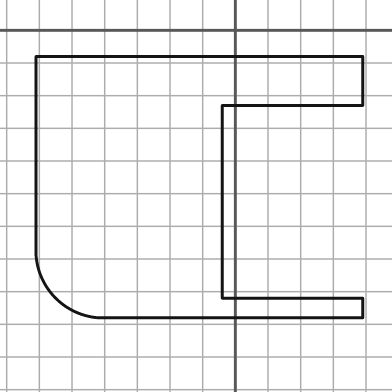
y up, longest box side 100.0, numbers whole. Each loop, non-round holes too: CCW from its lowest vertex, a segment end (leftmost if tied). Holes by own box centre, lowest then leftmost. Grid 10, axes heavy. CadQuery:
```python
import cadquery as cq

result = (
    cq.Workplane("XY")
    .moveTo(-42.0, -88.0)
    .lineTo(39.0, -88.0)
    .lineTo(39.0, -82.0)
    .lineTo(-4.0, -82.0)
    .lineTo(-4.0, -23.0)
    .lineTo(39.0, -23.0)
    .lineTo(39.0, -8.0)
    .lineTo(-61.0, -8.0)
    .lineTo(-61.0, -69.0)
    .threePointArc((-55.0, -82.0), (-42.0, -88.0))
    .close()
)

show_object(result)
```